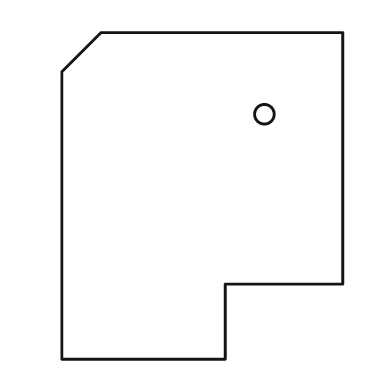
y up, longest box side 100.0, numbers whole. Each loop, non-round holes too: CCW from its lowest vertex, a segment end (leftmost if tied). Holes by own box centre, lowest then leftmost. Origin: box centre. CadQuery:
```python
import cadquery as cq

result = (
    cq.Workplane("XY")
    .moveTo(-43.0, -50.0)
    .lineTo(7.0, -50.0)
    .lineTo(7.0, -27.0)
    .lineTo(43.0, -27.0)
    .lineTo(43.0, 50.0)
    .lineTo(-31.0, 50.0)
    .lineTo(-43.0, 38.0)
    .close()
    .moveTo(19.0, 25.0)
    .circle(3.0)
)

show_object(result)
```